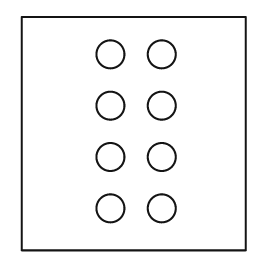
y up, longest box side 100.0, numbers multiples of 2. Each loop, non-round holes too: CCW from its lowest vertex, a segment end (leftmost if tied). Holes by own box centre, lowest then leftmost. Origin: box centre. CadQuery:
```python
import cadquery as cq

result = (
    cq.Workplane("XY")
    .moveTo(-48.0, -50.0)
    .lineTo(48.0, -50.0)
    .lineTo(48.0, 50.0)
    .lineTo(-48.0, 50.0)
    .close()
    .moveTo(-10.0, -32.0)
    .circle(6.0)
    .moveTo(12.0, -32.0)
    .circle(6.0)
    .moveTo(-10.0, -10.0)
    .circle(6.0)
    .moveTo(12.0, -10.0)
    .circle(6.0)
    .moveTo(-10.0, 12.0)
    .circle(6.0)
    .moveTo(12.0, 12.0)
    .circle(6.0)
    .moveTo(-10.0, 34.0)
    .circle(6.0)
    .moveTo(12.0, 34.0)
    .circle(6.0)
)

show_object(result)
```